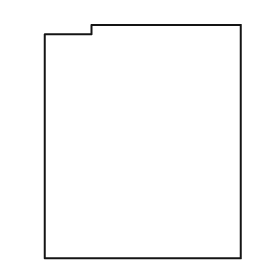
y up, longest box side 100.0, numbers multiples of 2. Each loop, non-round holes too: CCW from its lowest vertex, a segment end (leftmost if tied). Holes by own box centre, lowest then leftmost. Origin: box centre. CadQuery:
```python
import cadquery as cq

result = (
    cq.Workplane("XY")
    .moveTo(-42.0, -50.0)
    .lineTo(42.0, -50.0)
    .lineTo(42.0, 50.0)
    .lineTo(-22.0, 50.0)
    .lineTo(-22.0, 46.0)
    .lineTo(-42.0, 46.0)
    .close()
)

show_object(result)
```